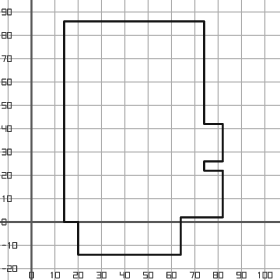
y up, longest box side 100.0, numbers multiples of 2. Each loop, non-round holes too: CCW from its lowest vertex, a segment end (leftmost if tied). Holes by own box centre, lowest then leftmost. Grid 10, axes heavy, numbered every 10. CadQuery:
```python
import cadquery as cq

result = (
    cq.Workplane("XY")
    .moveTo(20.0, -14.0)
    .lineTo(64.0, -14.0)
    .lineTo(64.0, 2.0)
    .lineTo(82.0, 2.0)
    .lineTo(82.0, 22.0)
    .lineTo(74.0, 22.0)
    .lineTo(74.0, 26.0)
    .lineTo(82.0, 26.0)
    .lineTo(82.0, 42.0)
    .lineTo(74.0, 42.0)
    .lineTo(74.0, 86.0)
    .lineTo(14.0, 86.0)
    .lineTo(14.0, 0.0)
    .lineTo(20.0, 0.0)
    .close()
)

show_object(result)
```